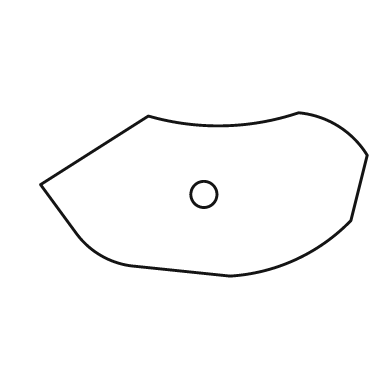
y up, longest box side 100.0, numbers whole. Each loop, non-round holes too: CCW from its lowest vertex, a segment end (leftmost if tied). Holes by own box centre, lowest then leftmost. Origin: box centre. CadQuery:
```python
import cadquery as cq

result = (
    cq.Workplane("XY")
    .moveTo(8.0, -25.0)
    .threePointArc((28.0, -20.0), (45.0, -8.0))
    .lineTo(50.0, 12.0)
    .threePointArc((41.0, 21.0), (29.0, 25.0))
    .threePointArc((6.0, 21.0), (-17.0, 24.0))
    .lineTo(-50.0, 3.0)
    .lineTo(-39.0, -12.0)
    .threePointArc((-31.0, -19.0), (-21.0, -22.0))
    .close()
    .moveTo(0.0, 0.0)
    .circle(4.0)
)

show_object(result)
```